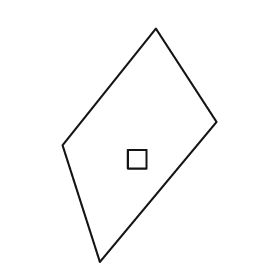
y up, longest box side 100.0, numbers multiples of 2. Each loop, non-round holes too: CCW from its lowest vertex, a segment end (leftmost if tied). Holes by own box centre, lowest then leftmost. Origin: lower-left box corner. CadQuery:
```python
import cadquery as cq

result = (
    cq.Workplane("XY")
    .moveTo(16.0, 0.0)
    .lineTo(66.0, 60.0)
    .lineTo(40.0, 100.0)
    .lineTo(0.0, 50.0)
    .close()
    .moveTo(28.0, 40.0)
    .lineTo(36.0, 40.0)
    .lineTo(36.0, 48.0)
    .lineTo(28.0, 48.0)
    .close()
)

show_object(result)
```